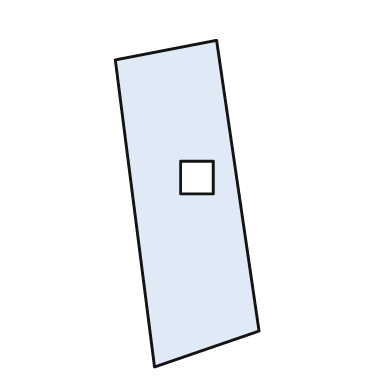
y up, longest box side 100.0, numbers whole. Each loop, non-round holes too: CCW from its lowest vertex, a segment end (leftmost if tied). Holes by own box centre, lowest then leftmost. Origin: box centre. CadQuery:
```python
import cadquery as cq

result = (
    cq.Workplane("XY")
    .moveTo(-10.0, -50.0)
    .lineTo(22.0, -39.0)
    .lineTo(9.0, 50.0)
    .lineTo(-22.0, 44.0)
    .close()
    .moveTo(-2.0, 3.0)
    .lineTo(8.0, 3.0)
    .lineTo(8.0, 13.0)
    .lineTo(-2.0, 13.0)
    .close()
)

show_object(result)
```